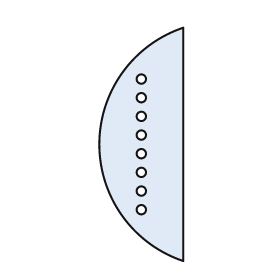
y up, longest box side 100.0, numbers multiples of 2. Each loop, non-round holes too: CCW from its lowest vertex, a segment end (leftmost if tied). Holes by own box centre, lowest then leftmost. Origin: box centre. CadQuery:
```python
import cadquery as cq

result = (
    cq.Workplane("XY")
    .moveTo(18.0, -50.0)
    .lineTo(18.0, 50.0)
    .threePointArc((-18.0, 0.0), (18.0, -50.0))
    .close()
    .moveTo(0.0, -28.0)
    .circle(2.0)
    .moveTo(0.0, -20.0)
    .circle(2.0)
    .moveTo(0.0, -12.0)
    .circle(2.0)
    .moveTo(0.0, -4.0)
    .circle(2.0)
    .moveTo(0.0, 4.0)
    .circle(2.0)
    .moveTo(0.0, 12.0)
    .circle(2.0)
    .moveTo(0.0, 20.0)
    .circle(2.0)
    .moveTo(0.0, 28.0)
    .circle(2.0)
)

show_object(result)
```